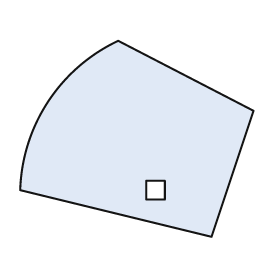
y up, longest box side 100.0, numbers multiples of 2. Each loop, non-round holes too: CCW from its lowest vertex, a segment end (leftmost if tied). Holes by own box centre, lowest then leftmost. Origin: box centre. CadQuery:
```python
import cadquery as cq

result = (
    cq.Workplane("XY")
    .moveTo(32.0, -42.0)
    .lineTo(50.0, 12.0)
    .lineTo(-8.0, 42.0)
    .threePointArc((-38.0, 16.0), (-50.0, -22.0))
    .close()
    .moveTo(4.0, -26.0)
    .lineTo(12.0, -26.0)
    .lineTo(12.0, -18.0)
    .lineTo(4.0, -18.0)
    .close()
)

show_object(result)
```